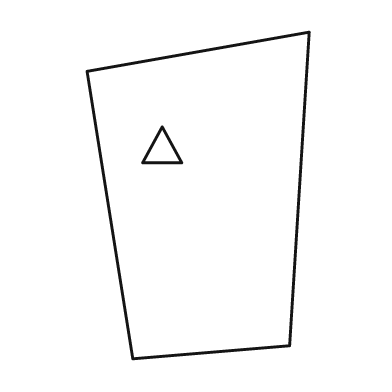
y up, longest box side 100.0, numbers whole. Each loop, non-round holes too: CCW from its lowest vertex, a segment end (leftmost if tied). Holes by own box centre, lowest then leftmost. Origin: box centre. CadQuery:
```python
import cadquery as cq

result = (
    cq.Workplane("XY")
    .moveTo(-20.0, -50.0)
    .lineTo(28.0, -46.0)
    .lineTo(34.0, 50.0)
    .lineTo(-34.0, 38.0)
    .close()
    .moveTo(-17.0, 10.0)
    .lineTo(-5.0, 10.0)
    .lineTo(-11.0, 21.0)
    .close()
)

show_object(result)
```